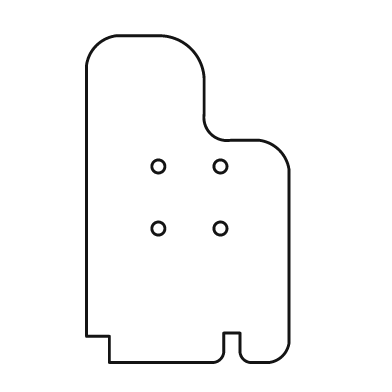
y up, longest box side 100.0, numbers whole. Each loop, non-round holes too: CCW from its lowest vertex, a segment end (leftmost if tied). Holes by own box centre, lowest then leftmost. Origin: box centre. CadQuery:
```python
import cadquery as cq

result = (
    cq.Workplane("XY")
    .moveTo(-24.0, -50.0)
    .lineTo(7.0, -50.0)
    .threePointArc((10.0, -49.0), (11.0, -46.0))
    .lineTo(11.0, -41.0)
    .lineTo(16.0, -41.0)
    .lineTo(16.0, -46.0)
    .threePointArc((17.0, -49.0), (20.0, -50.0))
    .lineTo(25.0, -50.0)
    .threePointArc((29.0, -48.0), (31.0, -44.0))
    .lineTo(31.0, 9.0)
    .threePointArc((28.0, 15.0), (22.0, 18.0))
    .lineTo(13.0, 18.0)
    .threePointArc((7.0, 20.0), (5.0, 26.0))
    .lineTo(5.0, 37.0)
    .threePointArc((1.0, 46.0), (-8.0, 50.0))
    .lineTo(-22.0, 50.0)
    .threePointArc((-28.0, 47.0), (-31.0, 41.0))
    .lineTo(-31.0, -42.0)
    .lineTo(-24.0, -42.0)
    .close()
    .moveTo(-9.0, -9.0)
    .circle(2.0)
    .moveTo(10.0, -9.0)
    .circle(2.0)
    .moveTo(-9.0, 10.0)
    .circle(2.0)
    .moveTo(10.0, 10.0)
    .circle(2.0)
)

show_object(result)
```